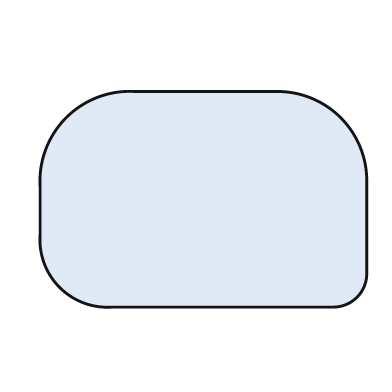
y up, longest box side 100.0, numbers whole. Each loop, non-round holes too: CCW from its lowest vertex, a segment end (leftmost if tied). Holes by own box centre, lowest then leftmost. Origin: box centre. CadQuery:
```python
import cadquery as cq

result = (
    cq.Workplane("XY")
    .moveTo(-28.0, -33.0)
    .lineTo(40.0, -33.0)
    .threePointArc((47.0, -30.0), (50.0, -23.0))
    .lineTo(50.0, 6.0)
    .threePointArc((42.0, 25.0), (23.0, 33.0))
    .lineTo(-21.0, 33.0)
    .threePointArc((-42.0, 25.0), (-50.0, 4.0))
    .lineTo(-50.0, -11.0)
    .threePointArc((-44.0, -27.0), (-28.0, -33.0))
    .close()
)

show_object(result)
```